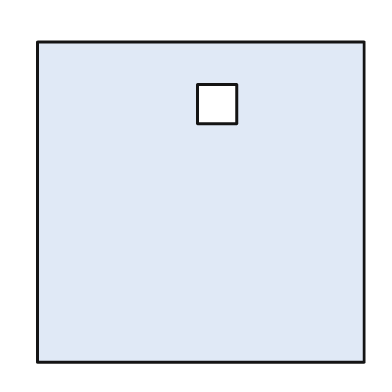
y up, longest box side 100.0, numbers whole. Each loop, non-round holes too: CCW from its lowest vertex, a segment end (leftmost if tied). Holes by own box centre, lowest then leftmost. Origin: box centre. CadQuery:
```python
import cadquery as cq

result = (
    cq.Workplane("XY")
    .moveTo(-50.0, -49.0)
    .lineTo(50.0, -49.0)
    .lineTo(50.0, 49.0)
    .lineTo(-50.0, 49.0)
    .close()
    .moveTo(-1.0, 24.0)
    .lineTo(11.0, 24.0)
    .lineTo(11.0, 36.0)
    .lineTo(-1.0, 36.0)
    .close()
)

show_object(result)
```